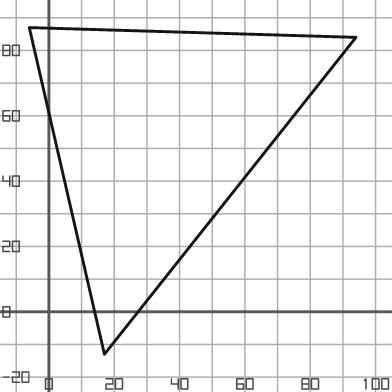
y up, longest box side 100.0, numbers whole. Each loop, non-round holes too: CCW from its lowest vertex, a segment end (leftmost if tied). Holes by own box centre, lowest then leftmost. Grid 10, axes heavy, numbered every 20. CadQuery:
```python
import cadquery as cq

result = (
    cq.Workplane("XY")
    .moveTo(17.0, -13.0)
    .lineTo(94.0, 84.0)
    .lineTo(-6.0, 87.0)
    .close()
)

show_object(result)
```